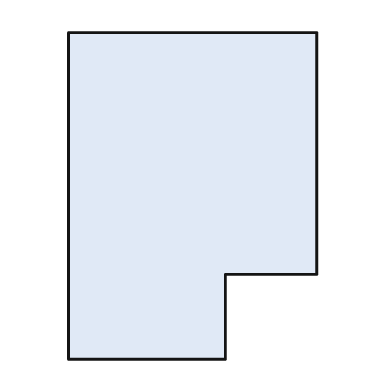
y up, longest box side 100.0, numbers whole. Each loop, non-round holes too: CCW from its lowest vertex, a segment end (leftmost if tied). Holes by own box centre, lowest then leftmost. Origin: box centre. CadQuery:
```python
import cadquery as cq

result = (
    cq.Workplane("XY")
    .moveTo(-38.0, -50.0)
    .lineTo(10.0, -50.0)
    .lineTo(10.0, -24.0)
    .lineTo(38.0, -24.0)
    .lineTo(38.0, 50.0)
    .lineTo(-38.0, 50.0)
    .close()
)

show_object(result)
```